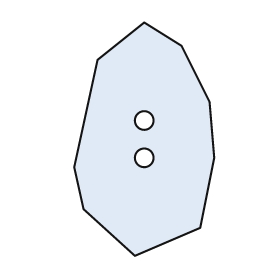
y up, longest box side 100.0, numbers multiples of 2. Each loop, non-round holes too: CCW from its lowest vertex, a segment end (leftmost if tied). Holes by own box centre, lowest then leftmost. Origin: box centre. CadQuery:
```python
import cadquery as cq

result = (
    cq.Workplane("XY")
    .moveTo(-4.0, -50.0)
    .lineTo(24.0, -38.0)
    .lineTo(30.0, -8.0)
    .lineTo(28.0, 16.0)
    .lineTo(16.0, 40.0)
    .lineTo(0.0, 50.0)
    .lineTo(-20.0, 34.0)
    .lineTo(-30.0, -12.0)
    .lineTo(-26.0, -30.0)
    .close()
    .moveTo(0.0, -8.0)
    .circle(4.0)
    .moveTo(0.0, 8.0)
    .circle(4.0)
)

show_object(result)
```